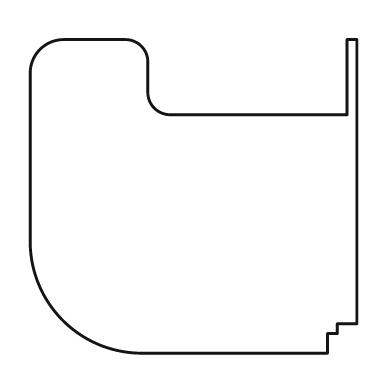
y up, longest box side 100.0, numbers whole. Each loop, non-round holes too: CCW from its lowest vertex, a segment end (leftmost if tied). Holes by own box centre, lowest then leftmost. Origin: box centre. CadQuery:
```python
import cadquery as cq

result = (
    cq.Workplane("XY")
    .moveTo(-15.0, -48.0)
    .lineTo(41.0, -48.0)
    .lineTo(41.0, -42.0)
    .lineTo(44.0, -42.0)
    .lineTo(44.0, -39.0)
    .lineTo(50.0, -39.0)
    .lineTo(50.0, 48.0)
    .lineTo(47.0, 48.0)
    .lineTo(47.0, 25.0)
    .lineTo(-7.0, 25.0)
    .threePointArc((-12.0, 27.0), (-14.0, 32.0))
    .lineTo(-14.0, 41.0)
    .threePointArc((-16.0, 46.0), (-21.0, 48.0))
    .lineTo(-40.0, 48.0)
    .threePointArc((-47.0, 45.0), (-50.0, 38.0))
    .lineTo(-50.0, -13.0)
    .threePointArc((-40.0, -38.0), (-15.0, -48.0))
    .close()
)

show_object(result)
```